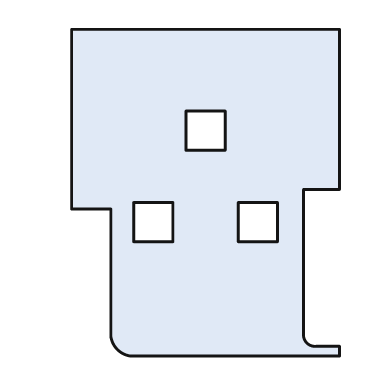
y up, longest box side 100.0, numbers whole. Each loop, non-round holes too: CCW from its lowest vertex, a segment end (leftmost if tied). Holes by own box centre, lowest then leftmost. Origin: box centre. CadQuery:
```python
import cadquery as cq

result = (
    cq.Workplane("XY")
    .moveTo(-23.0, -50.0)
    .lineTo(41.0, -50.0)
    .lineTo(41.0, -47.0)
    .lineTo(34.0, -47.0)
    .threePointArc((31.0, -46.0), (30.0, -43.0))
    .lineTo(30.0, 1.0)
    .lineTo(41.0, 1.0)
    .lineTo(41.0, 50.0)
    .lineTo(-41.0, 50.0)
    .lineTo(-41.0, -5.0)
    .lineTo(-29.0, -5.0)
    .lineTo(-29.0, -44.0)
    .threePointArc((-27.0, -48.0), (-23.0, -50.0))
    .close()
    .moveTo(-22.0, -15.0)
    .lineTo(-10.0, -15.0)
    .lineTo(-10.0, -3.0)
    .lineTo(-22.0, -3.0)
    .close()
    .moveTo(10.0, -15.0)
    .lineTo(22.0, -15.0)
    .lineTo(22.0, -3.0)
    .lineTo(10.0, -3.0)
    .close()
    .moveTo(-6.0, 13.0)
    .lineTo(6.0, 13.0)
    .lineTo(6.0, 25.0)
    .lineTo(-6.0, 25.0)
    .close()
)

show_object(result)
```